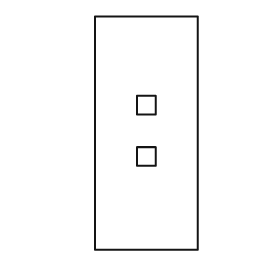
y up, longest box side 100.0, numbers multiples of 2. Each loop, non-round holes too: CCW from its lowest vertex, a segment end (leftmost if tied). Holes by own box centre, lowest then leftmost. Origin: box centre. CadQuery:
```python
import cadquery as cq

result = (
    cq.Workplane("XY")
    .moveTo(-22.0, -50.0)
    .lineTo(22.0, -50.0)
    .lineTo(22.0, 50.0)
    .lineTo(-22.0, 50.0)
    .close()
    .moveTo(-4.0, -14.0)
    .lineTo(4.0, -14.0)
    .lineTo(4.0, -6.0)
    .lineTo(-4.0, -6.0)
    .close()
    .moveTo(-4.0, 8.0)
    .lineTo(4.0, 8.0)
    .lineTo(4.0, 16.0)
    .lineTo(-4.0, 16.0)
    .close()
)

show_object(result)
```